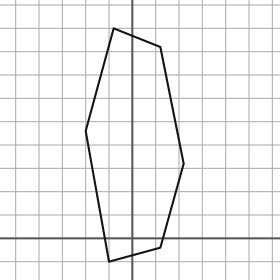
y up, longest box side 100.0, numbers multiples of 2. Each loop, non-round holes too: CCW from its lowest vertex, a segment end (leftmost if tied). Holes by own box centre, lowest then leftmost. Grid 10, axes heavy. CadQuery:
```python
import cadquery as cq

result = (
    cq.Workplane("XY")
    .moveTo(-10.0, -10.0)
    .lineTo(12.0, -4.0)
    .lineTo(22.0, 32.0)
    .lineTo(12.0, 82.0)
    .lineTo(-8.0, 90.0)
    .lineTo(-20.0, 46.0)
    .close()
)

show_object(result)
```